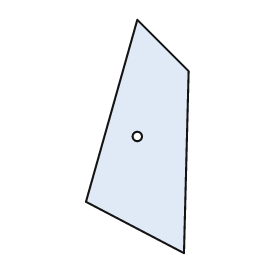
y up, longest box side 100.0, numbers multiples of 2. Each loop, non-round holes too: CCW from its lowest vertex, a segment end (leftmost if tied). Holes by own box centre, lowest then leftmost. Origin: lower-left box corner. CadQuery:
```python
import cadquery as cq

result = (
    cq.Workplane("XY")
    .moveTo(42.0, 0.0)
    .lineTo(44.0, 78.0)
    .lineTo(22.0, 100.0)
    .lineTo(0.0, 22.0)
    .close()
    .moveTo(22.0, 50.0)
    .circle(2.0)
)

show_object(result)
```